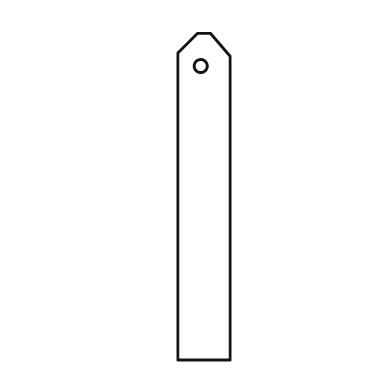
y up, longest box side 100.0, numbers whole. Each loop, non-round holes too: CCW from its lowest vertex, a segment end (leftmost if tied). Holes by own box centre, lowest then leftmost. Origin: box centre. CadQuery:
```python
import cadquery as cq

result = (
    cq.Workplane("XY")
    .moveTo(-8.0, -50.0)
    .lineTo(8.0, -50.0)
    .lineTo(8.0, 43.0)
    .lineTo(2.0, 50.0)
    .lineTo(-2.0, 50.0)
    .lineTo(-8.0, 44.0)
    .close()
    .moveTo(-1.0, 40.0)
    .circle(2.0)
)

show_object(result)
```